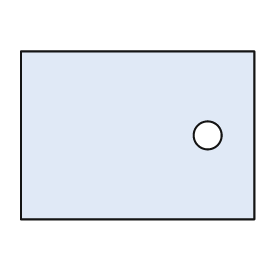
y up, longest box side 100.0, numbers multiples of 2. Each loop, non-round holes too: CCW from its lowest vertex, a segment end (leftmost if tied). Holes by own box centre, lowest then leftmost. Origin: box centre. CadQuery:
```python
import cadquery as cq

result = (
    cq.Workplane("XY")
    .moveTo(-50.0, -36.0)
    .lineTo(50.0, -36.0)
    .lineTo(50.0, 36.0)
    .lineTo(-50.0, 36.0)
    .close()
    .moveTo(30.0, 0.0)
    .circle(6.0)
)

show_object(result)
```